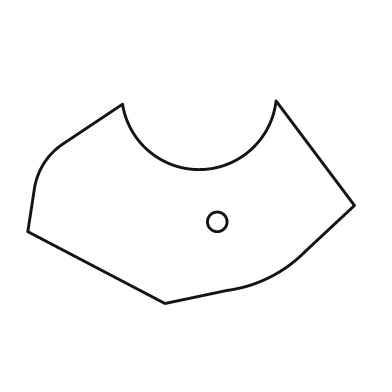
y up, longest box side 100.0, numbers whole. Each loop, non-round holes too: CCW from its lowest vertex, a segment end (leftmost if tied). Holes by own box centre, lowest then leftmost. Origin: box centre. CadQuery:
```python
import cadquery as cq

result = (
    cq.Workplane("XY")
    .moveTo(-8.0, -31.0)
    .lineTo(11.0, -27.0)
    .threePointArc((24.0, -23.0), (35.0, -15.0))
    .lineTo(50.0, -1.0)
    .lineTo(26.0, 31.0)
    .threePointArc((3.0, 10.0), (-21.0, 30.0))
    .lineTo(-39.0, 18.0)
    .threePointArc((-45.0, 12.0), (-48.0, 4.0))
    .lineTo(-50.0, -9.0)
    .close()
    .moveTo(8.0, -6.0)
    .circle(3.0)
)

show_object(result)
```